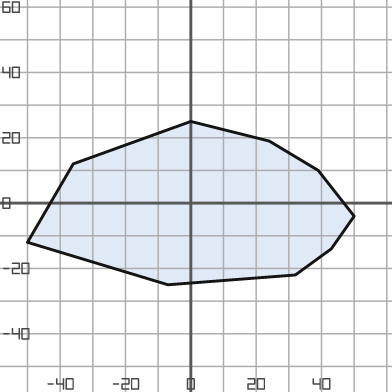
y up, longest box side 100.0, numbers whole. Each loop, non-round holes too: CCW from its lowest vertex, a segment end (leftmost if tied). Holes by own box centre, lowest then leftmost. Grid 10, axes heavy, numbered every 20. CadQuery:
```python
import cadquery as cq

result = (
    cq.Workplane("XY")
    .moveTo(-7.0, -25.0)
    .lineTo(32.0, -22.0)
    .lineTo(43.0, -14.0)
    .lineTo(50.0, -4.0)
    .lineTo(39.0, 10.0)
    .lineTo(24.0, 19.0)
    .lineTo(0.0, 25.0)
    .lineTo(-36.0, 12.0)
    .lineTo(-50.0, -12.0)
    .close()
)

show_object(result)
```